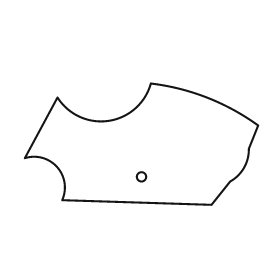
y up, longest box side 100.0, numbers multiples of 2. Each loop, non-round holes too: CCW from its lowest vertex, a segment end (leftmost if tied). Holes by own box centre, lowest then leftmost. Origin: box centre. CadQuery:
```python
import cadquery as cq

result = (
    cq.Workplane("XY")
    .moveTo(30.0, -26.0)
    .lineTo(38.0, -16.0)
    .threePointArc((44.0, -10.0), (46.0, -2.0))
    .lineTo(50.0, 8.0)
    .threePointArc((28.0, 20.0), (4.0, 26.0))
    .threePointArc((-14.0, 10.0), (-36.0, 20.0))
    .lineTo(-50.0, -6.0)
    .threePointArc((-36.0, -10.0), (-34.0, -24.0))
    .close()
    .moveTo(0.0, -14.0)
    .circle(2.0)
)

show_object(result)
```